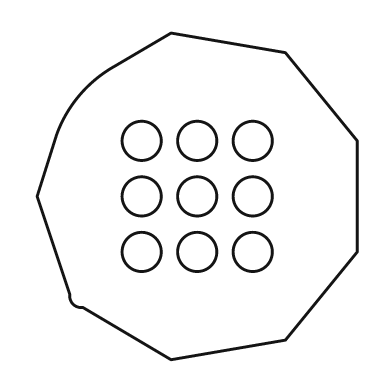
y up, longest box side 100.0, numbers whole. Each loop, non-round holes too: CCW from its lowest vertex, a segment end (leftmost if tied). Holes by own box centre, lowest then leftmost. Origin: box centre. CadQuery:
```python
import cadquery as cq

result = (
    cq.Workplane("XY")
    .moveTo(-8.0, -50.0)
    .lineTo(27.0, -44.0)
    .lineTo(49.0, -17.0)
    .lineTo(49.0, 17.0)
    .lineTo(27.0, 44.0)
    .lineTo(-8.0, 50.0)
    .lineTo(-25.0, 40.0)
    .threePointArc((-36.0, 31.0), (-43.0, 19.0))
    .lineTo(-49.0, 0.0)
    .lineTo(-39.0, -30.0)
    .threePointArc((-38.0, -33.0), (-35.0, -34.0))
    .close()
    .moveTo(-17.0, -17.0)
    .circle(6.0)
    .moveTo(0.0, -17.0)
    .circle(6.0)
    .moveTo(17.0, -17.0)
    .circle(6.0)
    .moveTo(-17.0, 0.0)
    .circle(6.0)
    .moveTo(0.0, 0.0)
    .circle(6.0)
    .moveTo(17.0, 0.0)
    .circle(6.0)
    .moveTo(-17.0, 17.0)
    .circle(6.0)
    .moveTo(0.0, 17.0)
    .circle(6.0)
    .moveTo(17.0, 17.0)
    .circle(6.0)
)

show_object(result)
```